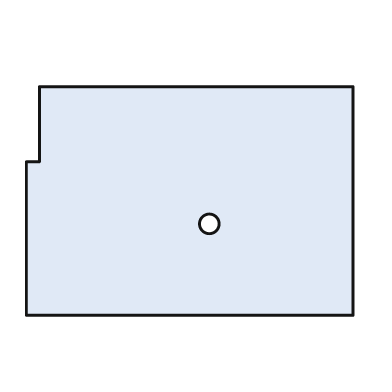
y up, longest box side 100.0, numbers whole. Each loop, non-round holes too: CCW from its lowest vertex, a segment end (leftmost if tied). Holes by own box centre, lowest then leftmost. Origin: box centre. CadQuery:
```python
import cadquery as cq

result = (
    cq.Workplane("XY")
    .moveTo(-50.0, -35.0)
    .lineTo(50.0, -35.0)
    .lineTo(50.0, 35.0)
    .lineTo(-46.0, 35.0)
    .lineTo(-46.0, 12.0)
    .lineTo(-50.0, 12.0)
    .close()
    .moveTo(6.0, -7.0)
    .circle(3.0)
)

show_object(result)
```